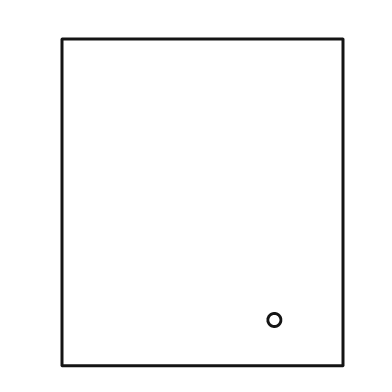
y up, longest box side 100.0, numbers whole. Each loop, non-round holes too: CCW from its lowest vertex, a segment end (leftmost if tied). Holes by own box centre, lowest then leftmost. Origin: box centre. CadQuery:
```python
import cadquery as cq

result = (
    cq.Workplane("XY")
    .moveTo(-43.0, -50.0)
    .lineTo(43.0, -50.0)
    .lineTo(43.0, 50.0)
    .lineTo(-43.0, 50.0)
    .close()
    .moveTo(22.0, -36.0)
    .circle(2.0)
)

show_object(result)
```